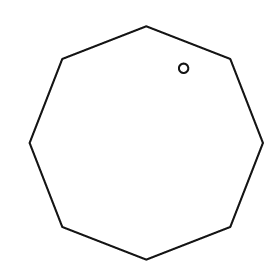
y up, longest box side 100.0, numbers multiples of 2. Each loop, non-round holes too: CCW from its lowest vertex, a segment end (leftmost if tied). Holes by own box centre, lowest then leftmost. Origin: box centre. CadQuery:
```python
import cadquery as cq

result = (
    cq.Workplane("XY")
    .moveTo(0.0, -50.0)
    .lineTo(36.0, -36.0)
    .lineTo(50.0, 0.0)
    .lineTo(36.0, 36.0)
    .lineTo(0.0, 50.0)
    .lineTo(-36.0, 36.0)
    .lineTo(-50.0, 0.0)
    .lineTo(-36.0, -36.0)
    .close()
    .moveTo(16.0, 32.0)
    .circle(2.0)
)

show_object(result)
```